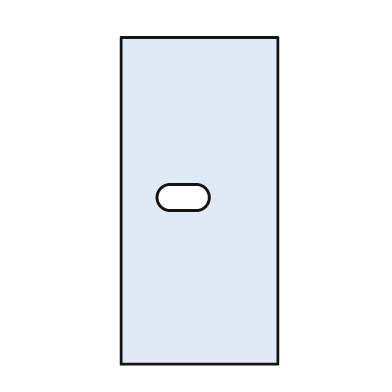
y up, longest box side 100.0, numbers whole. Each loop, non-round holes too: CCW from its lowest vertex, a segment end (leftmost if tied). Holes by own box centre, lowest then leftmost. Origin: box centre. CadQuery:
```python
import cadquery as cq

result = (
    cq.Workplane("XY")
    .moveTo(-24.0, -50.0)
    .lineTo(24.0, -50.0)
    .lineTo(24.0, 50.0)
    .lineTo(-24.0, 50.0)
    .close()
    .moveTo(-9.0, -3.0)
    .lineTo(-1.0, -3.0)
    .threePointArc((3.0, 1.0), (-1.0, 5.0))
    .lineTo(-9.0, 5.0)
    .threePointArc((-13.0, 1.0), (-9.0, -3.0))
    .close()
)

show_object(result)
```